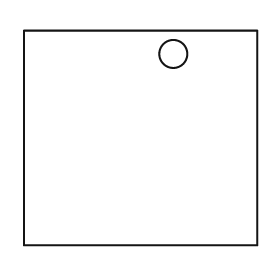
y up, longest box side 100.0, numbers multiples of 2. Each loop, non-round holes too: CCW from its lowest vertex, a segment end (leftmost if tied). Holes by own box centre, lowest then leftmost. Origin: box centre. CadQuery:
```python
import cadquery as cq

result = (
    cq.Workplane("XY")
    .moveTo(-50.0, -46.0)
    .lineTo(50.0, -46.0)
    .lineTo(50.0, 46.0)
    .lineTo(-50.0, 46.0)
    .close()
    .moveTo(14.0, 36.0)
    .circle(6.0)
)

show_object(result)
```